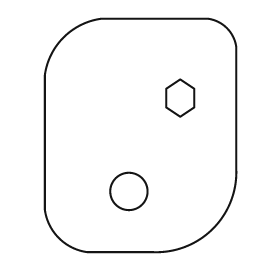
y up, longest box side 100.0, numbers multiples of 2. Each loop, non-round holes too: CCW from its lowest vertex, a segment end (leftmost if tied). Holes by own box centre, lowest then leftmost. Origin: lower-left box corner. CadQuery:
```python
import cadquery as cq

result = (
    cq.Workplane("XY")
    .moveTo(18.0, 0.0)
    .lineTo(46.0, 0.0)
    .threePointArc((72.0, 10.0), (82.0, 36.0))
    .lineTo(82.0, 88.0)
    .threePointArc((78.0, 96.0), (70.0, 100.0))
    .lineTo(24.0, 100.0)
    .threePointArc((8.0, 92.0), (0.0, 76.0))
    .lineTo(0.0, 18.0)
    .threePointArc((6.0, 6.0), (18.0, 0.0))
    .close()
    .moveTo(36.0, 26.0)
    .circle(8.0)
    .moveTo(58.0, 58.0)
    .lineTo(64.0, 62.0)
    .lineTo(64.0, 70.0)
    .lineTo(58.0, 74.0)
    .lineTo(52.0, 70.0)
    .lineTo(52.0, 62.0)
    .close()
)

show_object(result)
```